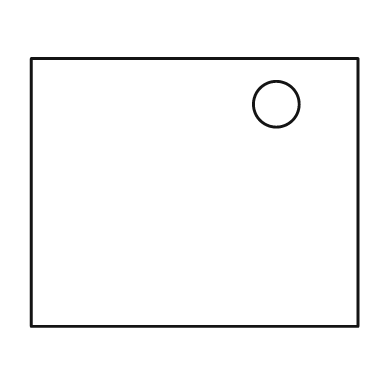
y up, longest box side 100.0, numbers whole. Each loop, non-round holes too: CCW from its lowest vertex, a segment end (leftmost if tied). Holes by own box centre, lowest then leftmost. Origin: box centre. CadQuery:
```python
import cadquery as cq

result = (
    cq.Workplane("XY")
    .moveTo(-50.0, -41.0)
    .lineTo(50.0, -41.0)
    .lineTo(50.0, 41.0)
    .lineTo(-50.0, 41.0)
    .close()
    .moveTo(25.0, 27.0)
    .circle(7.0)
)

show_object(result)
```